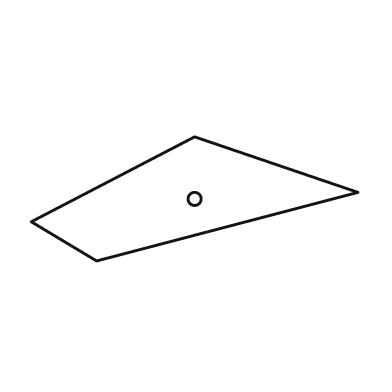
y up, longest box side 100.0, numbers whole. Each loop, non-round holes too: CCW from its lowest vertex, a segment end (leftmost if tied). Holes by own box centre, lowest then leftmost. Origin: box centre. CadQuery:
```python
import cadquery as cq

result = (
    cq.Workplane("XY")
    .moveTo(-30.0, -19.0)
    .lineTo(50.0, 2.0)
    .lineTo(0.0, 19.0)
    .lineTo(-50.0, -7.0)
    .close()
    .moveTo(0.0, 0.0)
    .circle(2.0)
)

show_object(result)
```